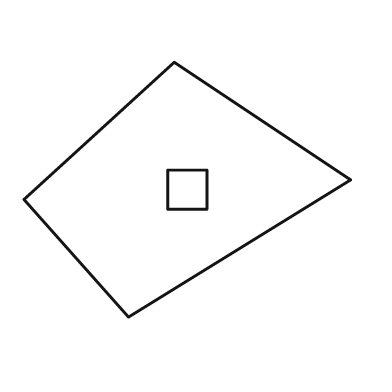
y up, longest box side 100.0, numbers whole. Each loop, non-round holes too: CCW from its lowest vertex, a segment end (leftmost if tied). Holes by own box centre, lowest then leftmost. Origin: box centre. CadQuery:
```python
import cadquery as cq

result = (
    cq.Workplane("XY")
    .moveTo(-18.0, -39.0)
    .lineTo(50.0, 3.0)
    .lineTo(-4.0, 39.0)
    .lineTo(-50.0, -3.0)
    .close()
    .moveTo(-6.0, -6.0)
    .lineTo(6.0, -6.0)
    .lineTo(6.0, 6.0)
    .lineTo(-6.0, 6.0)
    .close()
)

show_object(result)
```